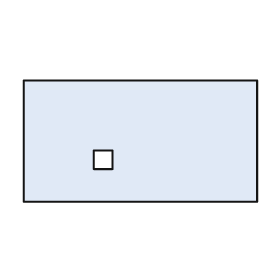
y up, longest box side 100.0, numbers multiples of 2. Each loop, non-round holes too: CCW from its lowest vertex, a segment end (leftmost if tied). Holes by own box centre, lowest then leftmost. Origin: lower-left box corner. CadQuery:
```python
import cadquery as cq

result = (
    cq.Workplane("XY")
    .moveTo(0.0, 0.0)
    .lineTo(100.0, 0.0)
    .lineTo(100.0, 52.0)
    .lineTo(0.0, 52.0)
    .close()
    .moveTo(30.0, 14.0)
    .lineTo(38.0, 14.0)
    .lineTo(38.0, 22.0)
    .lineTo(30.0, 22.0)
    .close()
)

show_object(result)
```